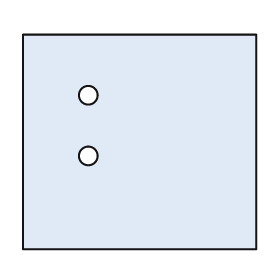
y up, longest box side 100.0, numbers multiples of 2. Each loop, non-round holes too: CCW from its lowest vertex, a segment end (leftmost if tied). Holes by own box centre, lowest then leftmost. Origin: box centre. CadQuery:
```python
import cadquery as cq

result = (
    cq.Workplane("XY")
    .moveTo(-50.0, -46.0)
    .lineTo(50.0, -46.0)
    .lineTo(50.0, 46.0)
    .lineTo(-50.0, 46.0)
    .close()
    .moveTo(-22.0, -6.0)
    .circle(4.0)
    .moveTo(-22.0, 20.0)
    .circle(4.0)
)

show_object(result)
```